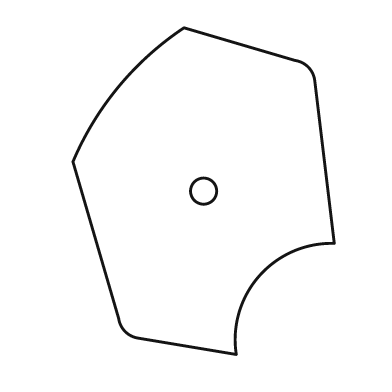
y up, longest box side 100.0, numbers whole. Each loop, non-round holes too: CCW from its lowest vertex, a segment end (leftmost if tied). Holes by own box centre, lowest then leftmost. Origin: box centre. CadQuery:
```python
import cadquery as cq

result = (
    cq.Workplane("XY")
    .moveTo(10.0, -50.0)
    .threePointArc((17.0, -26.0), (40.0, -16.0))
    .lineTo(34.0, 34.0)
    .threePointArc((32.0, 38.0), (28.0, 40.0))
    .lineTo(-6.0, 50.0)
    .threePointArc((-26.0, 32.0), (-40.0, 9.0))
    .lineTo(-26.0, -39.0)
    .threePointArc((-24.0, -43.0), (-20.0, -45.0))
    .close()
    .moveTo(0.0, 0.0)
    .circle(4.0)
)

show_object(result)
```